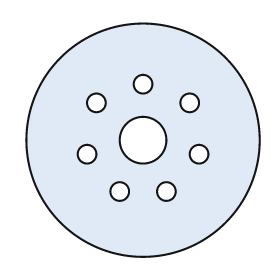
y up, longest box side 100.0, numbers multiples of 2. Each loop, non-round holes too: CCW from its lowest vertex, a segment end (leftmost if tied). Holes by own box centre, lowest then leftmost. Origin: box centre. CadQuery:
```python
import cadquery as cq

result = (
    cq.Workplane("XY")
    .moveTo(0.0, 0.0)
    .circle(50.0)
    .moveTo(-10.0, -22.0)
    .circle(4.0)
    .moveTo(10.0, -22.0)
    .circle(4.0)
    .moveTo(-24.0, -6.0)
    .circle(4.0)
    .moveTo(24.0, -6.0)
    .circle(4.0)
    .moveTo(0.0, 0.0)
    .circle(10.0)
    .moveTo(-20.0, 16.0)
    .circle(4.0)
    .moveTo(20.0, 16.0)
    .circle(4.0)
    .moveTo(0.0, 24.0)
    .circle(4.0)
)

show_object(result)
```